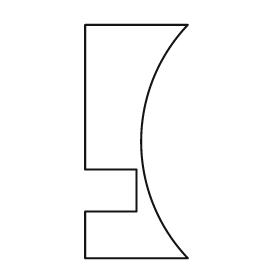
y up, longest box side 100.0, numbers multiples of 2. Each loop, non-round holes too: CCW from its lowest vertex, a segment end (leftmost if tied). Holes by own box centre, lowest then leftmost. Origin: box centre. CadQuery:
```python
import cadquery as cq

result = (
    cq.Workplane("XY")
    .moveTo(-22.0, -50.0)
    .lineTo(22.0, -50.0)
    .threePointArc((2.0, 0.0), (22.0, 50.0))
    .lineTo(-22.0, 50.0)
    .lineTo(-22.0, -12.0)
    .lineTo(0.0, -12.0)
    .lineTo(0.0, -30.0)
    .lineTo(-22.0, -30.0)
    .close()
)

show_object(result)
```